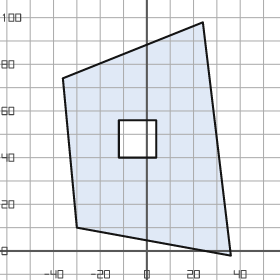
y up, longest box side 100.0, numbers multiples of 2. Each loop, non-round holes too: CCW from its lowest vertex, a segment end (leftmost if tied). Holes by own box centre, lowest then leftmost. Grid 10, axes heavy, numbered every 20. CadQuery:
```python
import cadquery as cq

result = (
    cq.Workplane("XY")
    .moveTo(36.0, -2.0)
    .lineTo(24.0, 98.0)
    .lineTo(-36.0, 74.0)
    .lineTo(-30.0, 10.0)
    .close()
    .moveTo(-12.0, 40.0)
    .lineTo(4.0, 40.0)
    .lineTo(4.0, 56.0)
    .lineTo(-12.0, 56.0)
    .close()
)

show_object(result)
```